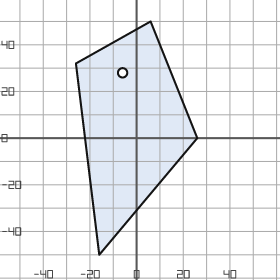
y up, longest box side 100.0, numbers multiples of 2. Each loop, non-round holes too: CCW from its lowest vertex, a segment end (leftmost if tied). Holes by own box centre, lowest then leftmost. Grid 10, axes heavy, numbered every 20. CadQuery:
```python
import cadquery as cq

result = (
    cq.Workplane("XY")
    .moveTo(-16.0, -50.0)
    .lineTo(26.0, 0.0)
    .lineTo(6.0, 50.0)
    .lineTo(-26.0, 32.0)
    .close()
    .moveTo(-6.0, 28.0)
    .circle(2.0)
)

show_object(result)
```